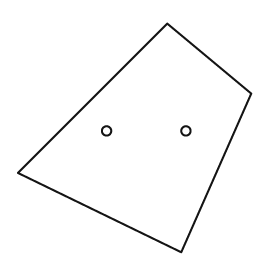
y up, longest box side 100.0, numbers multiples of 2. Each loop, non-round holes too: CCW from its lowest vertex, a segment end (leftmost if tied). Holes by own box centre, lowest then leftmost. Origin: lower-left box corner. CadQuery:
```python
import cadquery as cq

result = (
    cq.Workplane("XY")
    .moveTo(70.0, 0.0)
    .lineTo(100.0, 68.0)
    .lineTo(64.0, 98.0)
    .lineTo(0.0, 34.0)
    .close()
    .moveTo(38.0, 52.0)
    .circle(2.0)
    .moveTo(72.0, 52.0)
    .circle(2.0)
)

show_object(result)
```